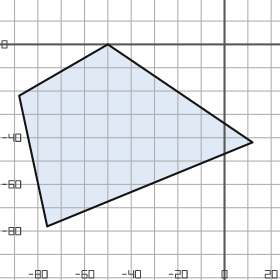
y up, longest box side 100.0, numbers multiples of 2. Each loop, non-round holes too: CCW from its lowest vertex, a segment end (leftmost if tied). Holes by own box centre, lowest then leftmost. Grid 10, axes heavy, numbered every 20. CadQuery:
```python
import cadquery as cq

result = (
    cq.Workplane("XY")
    .moveTo(-76.0, -78.0)
    .lineTo(12.0, -42.0)
    .lineTo(-50.0, 0.0)
    .lineTo(-88.0, -22.0)
    .close()
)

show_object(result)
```